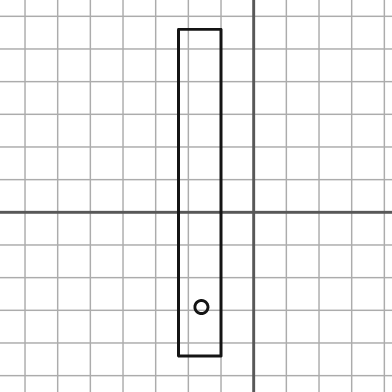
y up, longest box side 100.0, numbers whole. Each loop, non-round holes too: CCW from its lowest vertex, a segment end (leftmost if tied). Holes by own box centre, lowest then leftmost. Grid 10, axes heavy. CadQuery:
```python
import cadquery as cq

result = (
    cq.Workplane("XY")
    .moveTo(-23.0, -44.0)
    .lineTo(-10.0, -44.0)
    .lineTo(-10.0, 56.0)
    .lineTo(-23.0, 56.0)
    .close()
    .moveTo(-16.0, -29.0)
    .circle(2.0)
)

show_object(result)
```